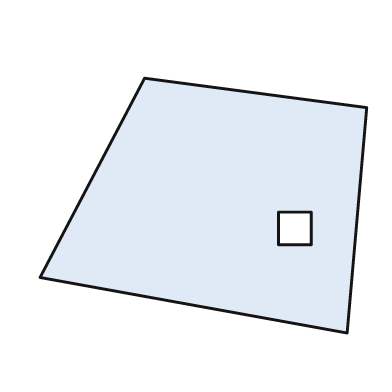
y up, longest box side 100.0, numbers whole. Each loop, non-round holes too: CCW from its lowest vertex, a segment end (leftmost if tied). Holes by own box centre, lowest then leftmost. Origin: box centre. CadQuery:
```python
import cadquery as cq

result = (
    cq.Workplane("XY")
    .moveTo(44.0, -39.0)
    .lineTo(50.0, 30.0)
    .lineTo(-18.0, 39.0)
    .lineTo(-50.0, -22.0)
    .close()
    .moveTo(23.0, -12.0)
    .lineTo(33.0, -12.0)
    .lineTo(33.0, -2.0)
    .lineTo(23.0, -2.0)
    .close()
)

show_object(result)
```